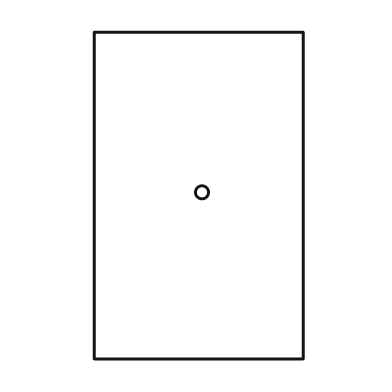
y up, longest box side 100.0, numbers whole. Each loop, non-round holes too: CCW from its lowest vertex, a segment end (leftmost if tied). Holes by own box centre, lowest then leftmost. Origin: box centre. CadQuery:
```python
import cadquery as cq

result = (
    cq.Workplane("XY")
    .moveTo(-32.0, -50.0)
    .lineTo(32.0, -50.0)
    .lineTo(32.0, 50.0)
    .lineTo(-32.0, 50.0)
    .close()
    .moveTo(1.0, 1.0)
    .circle(2.0)
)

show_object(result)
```